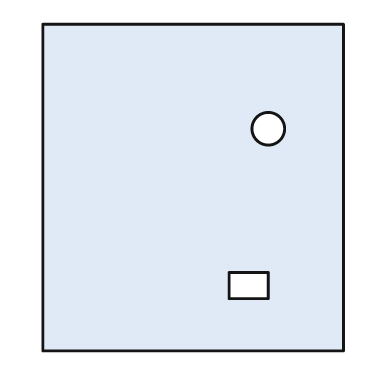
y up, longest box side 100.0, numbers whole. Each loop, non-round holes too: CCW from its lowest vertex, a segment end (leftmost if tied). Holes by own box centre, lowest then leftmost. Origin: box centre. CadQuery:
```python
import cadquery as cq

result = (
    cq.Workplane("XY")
    .moveTo(-46.0, -50.0)
    .lineTo(46.0, -50.0)
    .lineTo(46.0, 50.0)
    .lineTo(-46.0, 50.0)
    .close()
    .moveTo(11.0, -34.0)
    .lineTo(23.0, -34.0)
    .lineTo(23.0, -26.0)
    .lineTo(11.0, -26.0)
    .close()
    .moveTo(23.0, 18.0)
    .circle(5.0)
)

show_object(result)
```